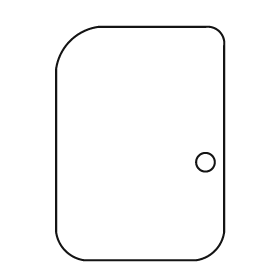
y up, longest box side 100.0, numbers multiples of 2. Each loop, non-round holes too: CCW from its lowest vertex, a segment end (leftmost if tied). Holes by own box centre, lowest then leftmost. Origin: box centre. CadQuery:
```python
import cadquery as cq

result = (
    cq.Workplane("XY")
    .moveTo(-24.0, -50.0)
    .lineTo(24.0, -50.0)
    .threePointArc((32.0, -46.0), (36.0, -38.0))
    .lineTo(36.0, 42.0)
    .threePointArc((34.0, 48.0), (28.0, 50.0))
    .lineTo(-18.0, 50.0)
    .threePointArc((-30.0, 44.0), (-36.0, 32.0))
    .lineTo(-36.0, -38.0)
    .threePointArc((-32.0, -46.0), (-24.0, -50.0))
    .close()
    .moveTo(28.0, -8.0)
    .circle(4.0)
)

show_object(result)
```